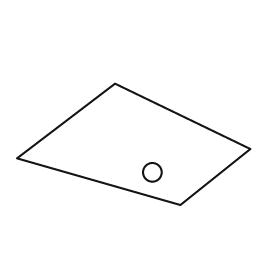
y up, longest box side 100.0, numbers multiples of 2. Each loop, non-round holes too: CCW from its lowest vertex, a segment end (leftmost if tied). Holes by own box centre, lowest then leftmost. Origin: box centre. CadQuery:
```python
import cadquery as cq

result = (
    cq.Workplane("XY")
    .moveTo(20.0, -26.0)
    .lineTo(50.0, -2.0)
    .lineTo(-8.0, 26.0)
    .lineTo(-50.0, -6.0)
    .close()
    .moveTo(8.0, -12.0)
    .circle(4.0)
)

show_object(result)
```